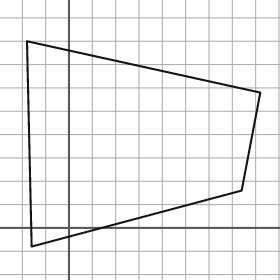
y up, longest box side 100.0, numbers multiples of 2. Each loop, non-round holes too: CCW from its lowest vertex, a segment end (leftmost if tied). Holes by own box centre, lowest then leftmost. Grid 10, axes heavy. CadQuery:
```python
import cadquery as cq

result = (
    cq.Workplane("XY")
    .moveTo(-16.0, -8.0)
    .lineTo(74.0, 16.0)
    .lineTo(82.0, 58.0)
    .lineTo(-18.0, 80.0)
    .close()
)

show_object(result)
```